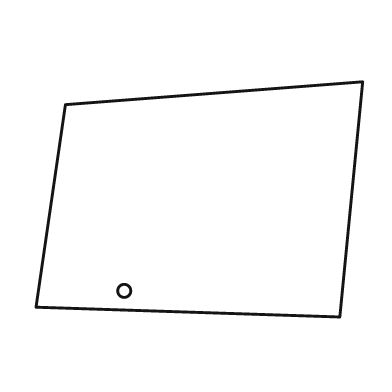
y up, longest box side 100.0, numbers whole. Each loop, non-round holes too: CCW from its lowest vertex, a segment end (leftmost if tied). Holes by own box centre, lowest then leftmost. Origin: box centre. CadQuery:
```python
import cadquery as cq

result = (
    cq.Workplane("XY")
    .moveTo(43.0, -36.0)
    .lineTo(50.0, 36.0)
    .lineTo(-41.0, 29.0)
    .lineTo(-50.0, -33.0)
    .close()
    .moveTo(-23.0, -28.0)
    .circle(2.0)
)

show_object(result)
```